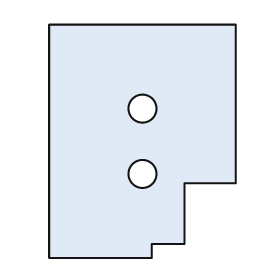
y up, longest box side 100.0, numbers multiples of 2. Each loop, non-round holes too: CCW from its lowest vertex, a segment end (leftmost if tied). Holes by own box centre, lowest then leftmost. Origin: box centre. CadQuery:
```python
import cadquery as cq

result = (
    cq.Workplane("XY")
    .moveTo(-40.0, -50.0)
    .lineTo(4.0, -50.0)
    .lineTo(4.0, -44.0)
    .lineTo(18.0, -44.0)
    .lineTo(18.0, -18.0)
    .lineTo(40.0, -18.0)
    .lineTo(40.0, 50.0)
    .lineTo(-40.0, 50.0)
    .close()
    .moveTo(0.0, -14.0)
    .circle(6.0)
    .moveTo(0.0, 14.0)
    .circle(6.0)
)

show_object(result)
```